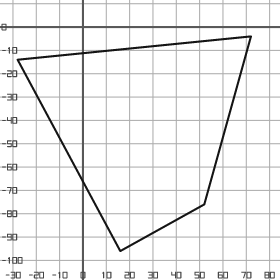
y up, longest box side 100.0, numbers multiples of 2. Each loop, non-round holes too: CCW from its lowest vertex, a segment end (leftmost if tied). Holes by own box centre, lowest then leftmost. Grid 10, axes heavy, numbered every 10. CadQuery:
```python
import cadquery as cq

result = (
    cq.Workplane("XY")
    .moveTo(16.0, -96.0)
    .lineTo(52.0, -76.0)
    .lineTo(72.0, -4.0)
    .lineTo(-28.0, -14.0)
    .close()
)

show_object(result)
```